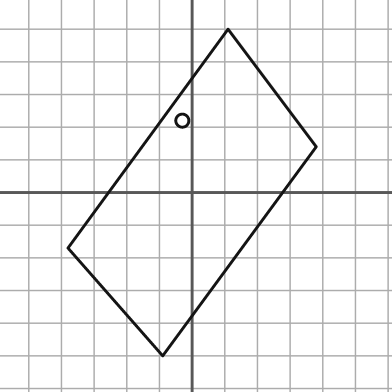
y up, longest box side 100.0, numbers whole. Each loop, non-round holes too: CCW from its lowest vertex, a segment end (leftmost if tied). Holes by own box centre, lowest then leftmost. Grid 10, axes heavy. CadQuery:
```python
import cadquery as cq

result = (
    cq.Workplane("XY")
    .moveTo(-9.0, -50.0)
    .lineTo(38.0, 14.0)
    .lineTo(11.0, 50.0)
    .lineTo(-38.0, -17.0)
    .close()
    .moveTo(-3.0, 22.0)
    .circle(2.0)
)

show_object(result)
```